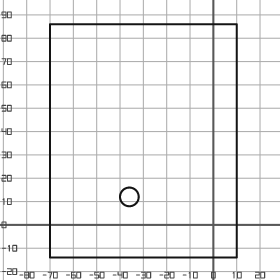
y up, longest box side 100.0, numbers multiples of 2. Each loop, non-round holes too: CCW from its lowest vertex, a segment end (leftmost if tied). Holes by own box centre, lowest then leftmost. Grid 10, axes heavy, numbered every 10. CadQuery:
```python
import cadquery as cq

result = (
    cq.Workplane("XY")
    .moveTo(-70.0, -14.0)
    .lineTo(10.0, -14.0)
    .lineTo(10.0, 86.0)
    .lineTo(-70.0, 86.0)
    .close()
    .moveTo(-36.0, 12.0)
    .circle(4.0)
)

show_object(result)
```